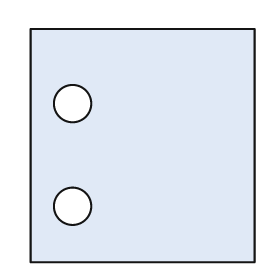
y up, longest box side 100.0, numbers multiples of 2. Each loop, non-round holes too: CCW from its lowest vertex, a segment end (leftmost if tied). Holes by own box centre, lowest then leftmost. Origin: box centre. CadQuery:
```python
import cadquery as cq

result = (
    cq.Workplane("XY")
    .moveTo(-48.0, -50.0)
    .lineTo(48.0, -50.0)
    .lineTo(48.0, 50.0)
    .lineTo(-48.0, 50.0)
    .close()
    .moveTo(-30.0, -26.0)
    .circle(8.0)
    .moveTo(-30.0, 18.0)
    .circle(8.0)
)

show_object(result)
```